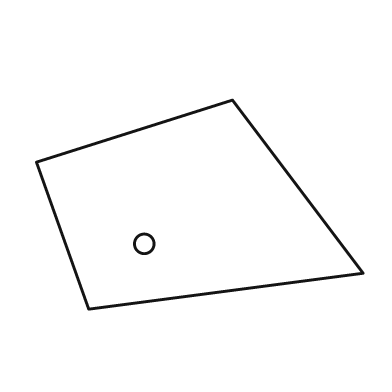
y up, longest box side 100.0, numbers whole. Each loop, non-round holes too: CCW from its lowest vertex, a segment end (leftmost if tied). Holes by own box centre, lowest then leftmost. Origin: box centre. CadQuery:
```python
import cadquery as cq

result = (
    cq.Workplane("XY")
    .moveTo(-34.0, -32.0)
    .lineTo(50.0, -21.0)
    .lineTo(10.0, 32.0)
    .lineTo(-50.0, 13.0)
    .close()
    .moveTo(-17.0, -12.0)
    .circle(3.0)
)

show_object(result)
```